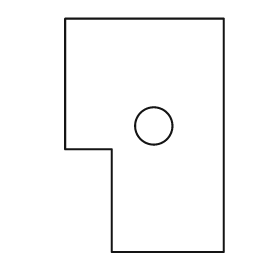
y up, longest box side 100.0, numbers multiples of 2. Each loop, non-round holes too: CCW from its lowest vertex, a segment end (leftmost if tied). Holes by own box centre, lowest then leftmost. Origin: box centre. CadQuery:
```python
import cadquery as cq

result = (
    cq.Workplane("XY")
    .moveTo(-14.0, -50.0)
    .lineTo(34.0, -50.0)
    .lineTo(34.0, 50.0)
    .lineTo(-34.0, 50.0)
    .lineTo(-34.0, -6.0)
    .lineTo(-14.0, -6.0)
    .close()
    .moveTo(4.0, 4.0)
    .circle(8.0)
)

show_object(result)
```